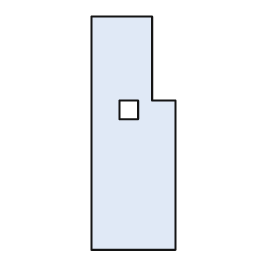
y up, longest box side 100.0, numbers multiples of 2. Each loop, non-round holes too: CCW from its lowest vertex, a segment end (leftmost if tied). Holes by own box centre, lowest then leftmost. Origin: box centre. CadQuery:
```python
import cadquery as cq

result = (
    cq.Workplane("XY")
    .moveTo(-18.0, -50.0)
    .lineTo(18.0, -50.0)
    .lineTo(18.0, 14.0)
    .lineTo(8.0, 14.0)
    .lineTo(8.0, 50.0)
    .lineTo(-18.0, 50.0)
    .close()
    .moveTo(-6.0, 6.0)
    .lineTo(2.0, 6.0)
    .lineTo(2.0, 14.0)
    .lineTo(-6.0, 14.0)
    .close()
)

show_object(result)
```